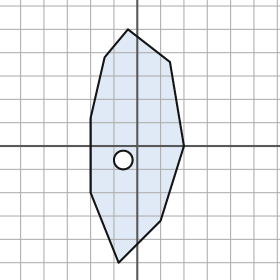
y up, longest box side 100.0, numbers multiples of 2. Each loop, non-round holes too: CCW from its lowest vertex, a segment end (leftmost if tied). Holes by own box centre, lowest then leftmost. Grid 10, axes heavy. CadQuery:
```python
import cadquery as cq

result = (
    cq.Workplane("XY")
    .moveTo(-8.0, -50.0)
    .lineTo(10.0, -32.0)
    .lineTo(20.0, 0.0)
    .lineTo(14.0, 36.0)
    .lineTo(-4.0, 50.0)
    .lineTo(-14.0, 38.0)
    .lineTo(-20.0, 12.0)
    .lineTo(-20.0, -20.0)
    .close()
    .moveTo(-6.0, -6.0)
    .circle(4.0)
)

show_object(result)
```